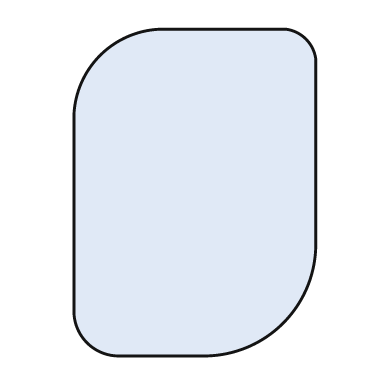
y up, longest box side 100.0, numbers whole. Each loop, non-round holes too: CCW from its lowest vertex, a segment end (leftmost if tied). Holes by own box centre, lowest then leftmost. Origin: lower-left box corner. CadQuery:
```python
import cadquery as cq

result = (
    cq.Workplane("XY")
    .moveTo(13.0, 0.0)
    .lineTo(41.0, 0.0)
    .threePointArc((64.0, 10.0), (74.0, 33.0))
    .lineTo(74.0, 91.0)
    .threePointArc((71.0, 97.0), (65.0, 100.0))
    .lineTo(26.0, 100.0)
    .threePointArc((8.0, 92.0), (0.0, 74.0))
    .lineTo(0.0, 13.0)
    .threePointArc((4.0, 4.0), (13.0, 0.0))
    .close()
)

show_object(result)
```